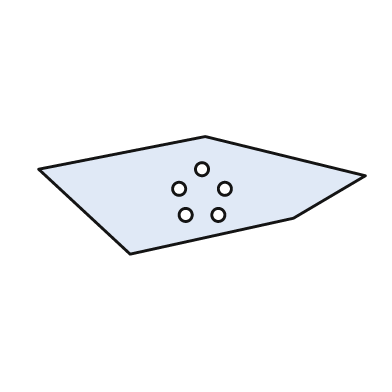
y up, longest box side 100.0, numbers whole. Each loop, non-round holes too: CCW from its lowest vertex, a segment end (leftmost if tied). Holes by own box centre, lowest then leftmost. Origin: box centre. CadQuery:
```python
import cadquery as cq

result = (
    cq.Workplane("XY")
    .moveTo(-22.0, -18.0)
    .lineTo(28.0, -7.0)
    .lineTo(50.0, 6.0)
    .lineTo(1.0, 18.0)
    .lineTo(-50.0, 8.0)
    .close()
    .moveTo(-5.0, -6.0)
    .circle(2.0)
    .moveTo(5.0, -6.0)
    .circle(2.0)
    .moveTo(-7.0, 2.0)
    .circle(2.0)
    .moveTo(7.0, 2.0)
    .circle(2.0)
    .moveTo(0.0, 8.0)
    .circle(2.0)
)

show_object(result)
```